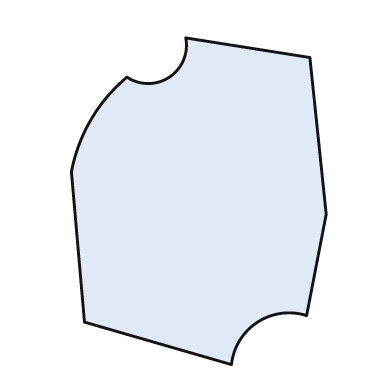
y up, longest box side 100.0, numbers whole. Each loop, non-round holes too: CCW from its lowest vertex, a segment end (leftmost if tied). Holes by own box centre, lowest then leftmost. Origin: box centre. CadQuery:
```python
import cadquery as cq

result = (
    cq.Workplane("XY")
    .moveTo(10.0, -50.0)
    .threePointArc((18.0, -37.0), (33.0, -35.0))
    .lineTo(39.0, -4.0)
    .lineTo(34.0, 44.0)
    .lineTo(-4.0, 50.0)
    .threePointArc((-9.0, 38.0), (-22.0, 38.0))
    .threePointArc((-33.0, 25.0), (-39.0, 9.0))
    .lineTo(-35.0, -37.0)
    .close()
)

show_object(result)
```